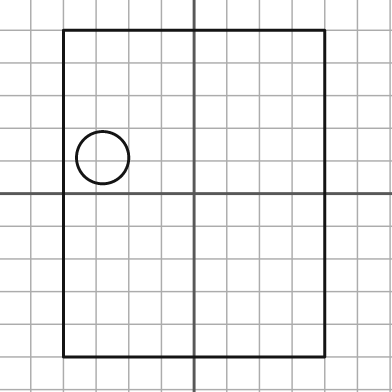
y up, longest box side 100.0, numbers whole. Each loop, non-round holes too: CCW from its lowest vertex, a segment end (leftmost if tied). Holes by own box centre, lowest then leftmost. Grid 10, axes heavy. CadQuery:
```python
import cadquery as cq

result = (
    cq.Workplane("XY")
    .moveTo(-40.0, -50.0)
    .lineTo(40.0, -50.0)
    .lineTo(40.0, 50.0)
    .lineTo(-40.0, 50.0)
    .close()
    .moveTo(-28.0, 11.0)
    .circle(8.0)
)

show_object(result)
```